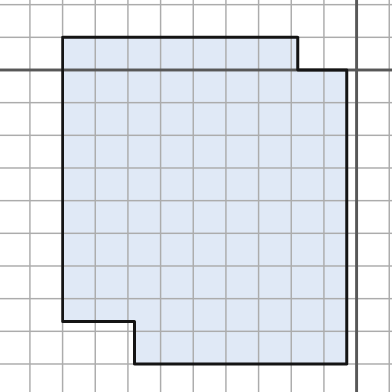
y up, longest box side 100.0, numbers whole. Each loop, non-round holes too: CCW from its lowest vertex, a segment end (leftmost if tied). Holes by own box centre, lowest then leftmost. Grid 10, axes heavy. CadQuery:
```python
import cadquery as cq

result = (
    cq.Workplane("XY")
    .moveTo(-68.0, -90.0)
    .lineTo(-3.0, -90.0)
    .lineTo(-3.0, 0.0)
    .lineTo(-18.0, 0.0)
    .lineTo(-18.0, 10.0)
    .lineTo(-90.0, 10.0)
    .lineTo(-90.0, -77.0)
    .lineTo(-68.0, -77.0)
    .close()
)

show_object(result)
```